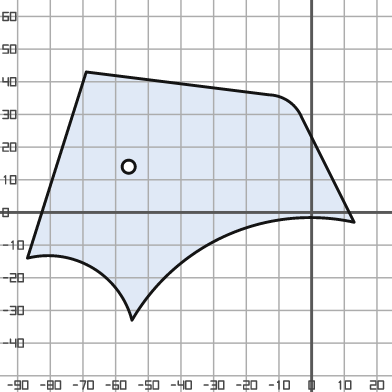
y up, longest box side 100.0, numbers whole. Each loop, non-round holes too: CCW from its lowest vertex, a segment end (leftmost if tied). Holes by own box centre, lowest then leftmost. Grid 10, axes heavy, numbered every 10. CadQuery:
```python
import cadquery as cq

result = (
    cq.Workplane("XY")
    .moveTo(-55.0, -33.0)
    .threePointArc((-26.0, -7.0), (13.0, -3.0))
    .lineTo(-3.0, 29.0)
    .threePointArc((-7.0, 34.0), (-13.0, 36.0))
    .lineTo(-69.0, 43.0)
    .lineTo(-87.0, -14.0)
    .threePointArc((-67.0, -17.0), (-55.0, -33.0))
    .close()
    .moveTo(-56.0, 14.0)
    .circle(2.0)
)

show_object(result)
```